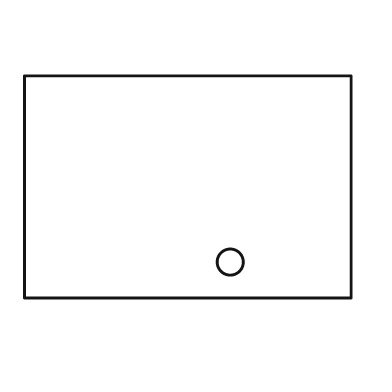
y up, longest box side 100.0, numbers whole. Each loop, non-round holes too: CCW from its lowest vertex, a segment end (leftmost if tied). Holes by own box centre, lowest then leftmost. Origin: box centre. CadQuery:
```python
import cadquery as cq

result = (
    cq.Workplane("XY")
    .moveTo(-50.0, -34.0)
    .lineTo(50.0, -34.0)
    .lineTo(50.0, 34.0)
    .lineTo(-50.0, 34.0)
    .close()
    .moveTo(13.0, -23.0)
    .circle(4.0)
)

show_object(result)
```